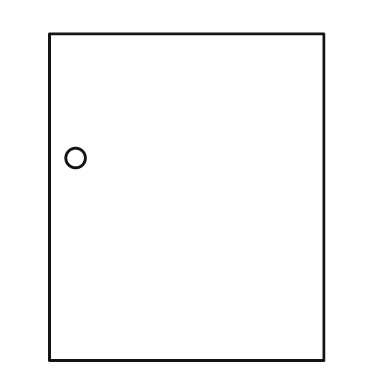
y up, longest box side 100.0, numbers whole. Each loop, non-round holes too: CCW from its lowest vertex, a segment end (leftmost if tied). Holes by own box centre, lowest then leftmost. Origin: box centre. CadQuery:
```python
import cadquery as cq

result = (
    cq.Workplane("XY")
    .moveTo(-42.0, -50.0)
    .lineTo(42.0, -50.0)
    .lineTo(42.0, 50.0)
    .lineTo(-42.0, 50.0)
    .close()
    .moveTo(-34.0, 12.0)
    .circle(3.0)
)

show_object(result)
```